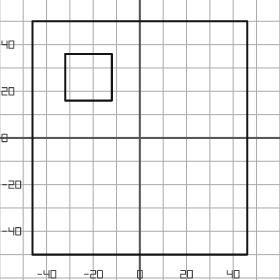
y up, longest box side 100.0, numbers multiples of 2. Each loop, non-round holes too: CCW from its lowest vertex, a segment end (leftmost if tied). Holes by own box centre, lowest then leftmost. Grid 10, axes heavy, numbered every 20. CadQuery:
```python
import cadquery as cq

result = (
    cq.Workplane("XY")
    .moveTo(-46.0, -50.0)
    .lineTo(46.0, -50.0)
    .lineTo(46.0, 50.0)
    .lineTo(-46.0, 50.0)
    .close()
    .moveTo(-32.0, 16.0)
    .lineTo(-12.0, 16.0)
    .lineTo(-12.0, 36.0)
    .lineTo(-32.0, 36.0)
    .close()
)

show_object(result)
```